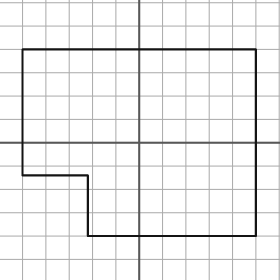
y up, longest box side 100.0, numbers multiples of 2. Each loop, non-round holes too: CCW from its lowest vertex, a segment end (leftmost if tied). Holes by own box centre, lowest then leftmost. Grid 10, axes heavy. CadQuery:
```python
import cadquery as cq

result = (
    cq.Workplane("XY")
    .moveTo(-22.0, -40.0)
    .lineTo(50.0, -40.0)
    .lineTo(50.0, 40.0)
    .lineTo(-50.0, 40.0)
    .lineTo(-50.0, -14.0)
    .lineTo(-22.0, -14.0)
    .close()
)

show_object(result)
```